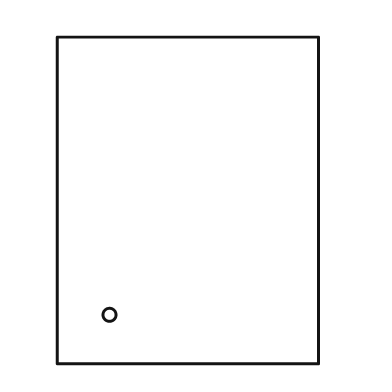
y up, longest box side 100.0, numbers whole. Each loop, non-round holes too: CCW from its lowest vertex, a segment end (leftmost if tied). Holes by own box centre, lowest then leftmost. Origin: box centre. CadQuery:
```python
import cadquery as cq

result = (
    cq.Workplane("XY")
    .moveTo(-40.0, -50.0)
    .lineTo(40.0, -50.0)
    .lineTo(40.0, 50.0)
    .lineTo(-40.0, 50.0)
    .close()
    .moveTo(-24.0, -35.0)
    .circle(2.0)
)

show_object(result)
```